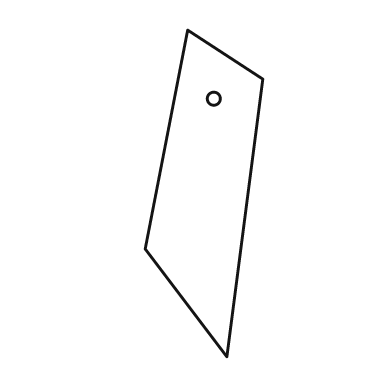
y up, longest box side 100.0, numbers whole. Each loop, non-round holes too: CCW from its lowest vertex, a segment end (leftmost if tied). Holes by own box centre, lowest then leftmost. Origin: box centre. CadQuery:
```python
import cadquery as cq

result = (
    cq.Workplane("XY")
    .moveTo(7.0, -50.0)
    .lineTo(18.0, 35.0)
    .lineTo(-5.0, 50.0)
    .lineTo(-18.0, -17.0)
    .close()
    .moveTo(3.0, 29.0)
    .circle(2.0)
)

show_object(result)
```